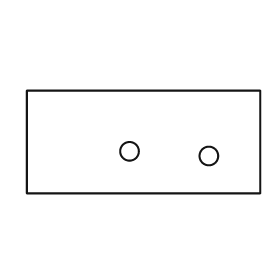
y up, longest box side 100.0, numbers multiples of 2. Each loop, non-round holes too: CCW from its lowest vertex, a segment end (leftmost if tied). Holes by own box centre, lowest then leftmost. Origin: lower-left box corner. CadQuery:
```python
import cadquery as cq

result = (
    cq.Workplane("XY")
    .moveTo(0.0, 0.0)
    .lineTo(100.0, 0.0)
    .lineTo(100.0, 44.0)
    .lineTo(0.0, 44.0)
    .close()
    .moveTo(78.0, 16.0)
    .circle(4.0)
    .moveTo(44.0, 18.0)
    .circle(4.0)
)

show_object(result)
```